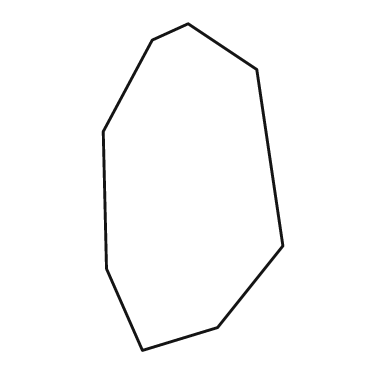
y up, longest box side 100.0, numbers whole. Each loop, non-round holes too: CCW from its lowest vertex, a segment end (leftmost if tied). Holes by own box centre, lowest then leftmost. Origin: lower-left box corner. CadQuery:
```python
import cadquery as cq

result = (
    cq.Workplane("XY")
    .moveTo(12.0, 0.0)
    .lineTo(35.0, 7.0)
    .lineTo(55.0, 32.0)
    .lineTo(47.0, 86.0)
    .lineTo(26.0, 100.0)
    .lineTo(15.0, 95.0)
    .lineTo(0.0, 67.0)
    .lineTo(1.0, 25.0)
    .close()
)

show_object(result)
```